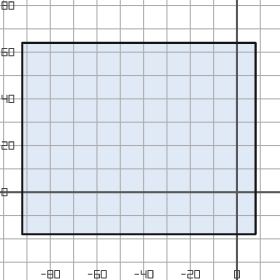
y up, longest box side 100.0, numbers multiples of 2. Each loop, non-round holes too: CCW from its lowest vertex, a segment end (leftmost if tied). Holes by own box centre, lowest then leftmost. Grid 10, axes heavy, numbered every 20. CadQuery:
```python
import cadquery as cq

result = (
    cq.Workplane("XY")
    .moveTo(-92.0, -18.0)
    .lineTo(8.0, -18.0)
    .lineTo(8.0, 64.0)
    .lineTo(-92.0, 64.0)
    .close()
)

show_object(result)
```